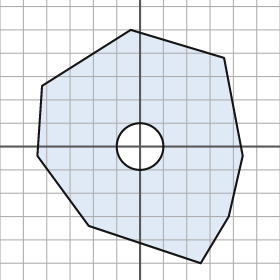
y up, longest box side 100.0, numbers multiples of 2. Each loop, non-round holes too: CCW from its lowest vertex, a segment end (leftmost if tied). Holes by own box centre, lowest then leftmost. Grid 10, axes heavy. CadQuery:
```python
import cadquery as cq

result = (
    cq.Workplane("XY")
    .moveTo(26.0, -50.0)
    .lineTo(38.0, -30.0)
    .lineTo(44.0, -4.0)
    .lineTo(36.0, 38.0)
    .lineTo(-4.0, 50.0)
    .lineTo(-42.0, 26.0)
    .lineTo(-44.0, -4.0)
    .lineTo(-22.0, -34.0)
    .close()
    .moveTo(0.0, 0.0)
    .circle(10.0)
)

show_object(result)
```